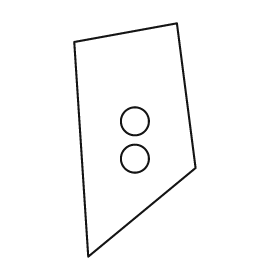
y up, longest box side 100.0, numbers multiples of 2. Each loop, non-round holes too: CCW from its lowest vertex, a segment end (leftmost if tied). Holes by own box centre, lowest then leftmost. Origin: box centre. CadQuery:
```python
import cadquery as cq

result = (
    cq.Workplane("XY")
    .moveTo(-20.0, -50.0)
    .lineTo(26.0, -12.0)
    .lineTo(18.0, 50.0)
    .lineTo(-26.0, 42.0)
    .close()
    .moveTo(0.0, -8.0)
    .circle(6.0)
    .moveTo(0.0, 8.0)
    .circle(6.0)
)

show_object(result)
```